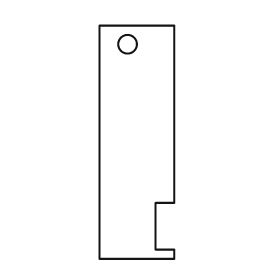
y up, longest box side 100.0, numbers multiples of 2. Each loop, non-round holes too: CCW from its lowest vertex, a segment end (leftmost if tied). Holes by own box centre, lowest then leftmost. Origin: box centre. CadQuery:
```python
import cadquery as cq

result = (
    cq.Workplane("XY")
    .moveTo(-16.0, -50.0)
    .lineTo(16.0, -50.0)
    .lineTo(16.0, -46.0)
    .lineTo(8.0, -46.0)
    .lineTo(8.0, -26.0)
    .lineTo(16.0, -26.0)
    .lineTo(16.0, 50.0)
    .lineTo(-16.0, 50.0)
    .close()
    .moveTo(-4.0, 42.0)
    .circle(4.0)
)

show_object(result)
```